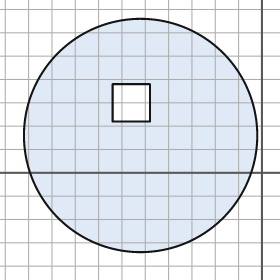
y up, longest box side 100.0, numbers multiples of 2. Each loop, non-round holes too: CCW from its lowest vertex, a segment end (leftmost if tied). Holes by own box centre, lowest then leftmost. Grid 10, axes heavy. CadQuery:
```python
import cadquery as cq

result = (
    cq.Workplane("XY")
    .moveTo(-52.0, 16.0)
    .circle(50.0)
    .moveTo(-64.0, 22.0)
    .lineTo(-48.0, 22.0)
    .lineTo(-48.0, 38.0)
    .lineTo(-64.0, 38.0)
    .close()
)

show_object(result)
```